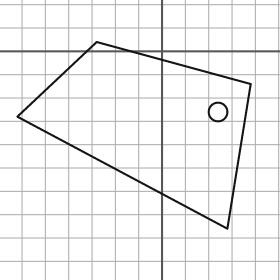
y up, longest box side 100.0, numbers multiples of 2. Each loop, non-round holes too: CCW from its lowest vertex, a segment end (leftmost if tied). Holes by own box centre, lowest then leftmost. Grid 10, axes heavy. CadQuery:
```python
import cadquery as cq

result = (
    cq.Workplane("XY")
    .moveTo(28.0, -76.0)
    .lineTo(38.0, -14.0)
    .lineTo(-28.0, 4.0)
    .lineTo(-62.0, -28.0)
    .close()
    .moveTo(24.0, -26.0)
    .circle(4.0)
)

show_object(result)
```